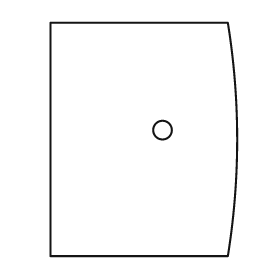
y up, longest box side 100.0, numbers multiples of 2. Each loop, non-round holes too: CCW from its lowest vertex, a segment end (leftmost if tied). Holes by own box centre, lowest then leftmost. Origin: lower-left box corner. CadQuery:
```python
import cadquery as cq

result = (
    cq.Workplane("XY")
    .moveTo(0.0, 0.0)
    .lineTo(76.0, 0.0)
    .threePointArc((80.0, 50.0), (76.0, 100.0))
    .lineTo(0.0, 100.0)
    .close()
    .moveTo(48.0, 54.0)
    .circle(4.0)
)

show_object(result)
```